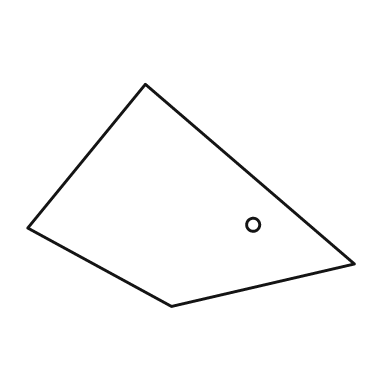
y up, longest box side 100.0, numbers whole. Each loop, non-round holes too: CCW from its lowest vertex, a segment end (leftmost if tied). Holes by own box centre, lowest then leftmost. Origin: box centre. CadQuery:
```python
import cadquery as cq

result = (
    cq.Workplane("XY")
    .moveTo(-6.0, -34.0)
    .lineTo(50.0, -21.0)
    .lineTo(-14.0, 34.0)
    .lineTo(-50.0, -10.0)
    .close()
    .moveTo(19.0, -9.0)
    .circle(2.0)
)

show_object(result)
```